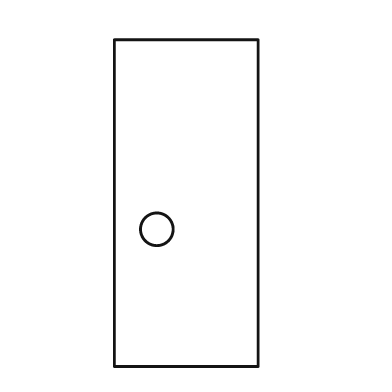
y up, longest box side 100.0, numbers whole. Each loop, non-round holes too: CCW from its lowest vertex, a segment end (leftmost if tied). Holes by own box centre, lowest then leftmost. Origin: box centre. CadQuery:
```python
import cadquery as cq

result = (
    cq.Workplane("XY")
    .moveTo(-22.0, -50.0)
    .lineTo(22.0, -50.0)
    .lineTo(22.0, 50.0)
    .lineTo(-22.0, 50.0)
    .close()
    .moveTo(-9.0, -8.0)
    .circle(5.0)
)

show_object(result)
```